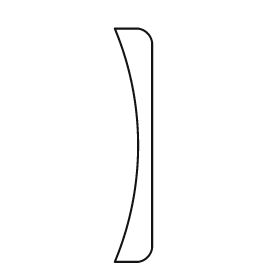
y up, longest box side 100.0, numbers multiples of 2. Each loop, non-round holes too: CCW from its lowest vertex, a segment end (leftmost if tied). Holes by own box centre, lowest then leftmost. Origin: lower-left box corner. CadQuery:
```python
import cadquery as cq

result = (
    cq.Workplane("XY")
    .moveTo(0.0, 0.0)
    .lineTo(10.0, 0.0)
    .threePointArc((14.0, 2.0), (16.0, 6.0))
    .lineTo(16.0, 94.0)
    .threePointArc((14.0, 98.0), (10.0, 100.0))
    .lineTo(0.0, 100.0)
    .threePointArc((10.0, 50.0), (0.0, 0.0))
    .close()
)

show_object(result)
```